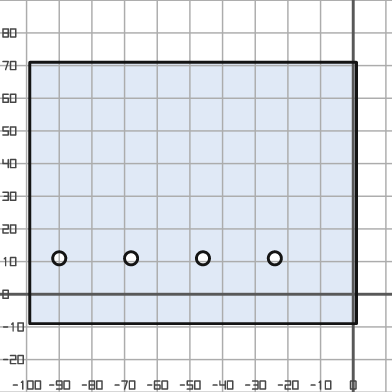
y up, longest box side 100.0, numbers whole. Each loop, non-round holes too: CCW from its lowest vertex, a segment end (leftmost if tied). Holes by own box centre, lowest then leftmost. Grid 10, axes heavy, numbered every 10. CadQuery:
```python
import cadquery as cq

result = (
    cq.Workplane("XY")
    .moveTo(-99.0, -9.0)
    .lineTo(1.0, -9.0)
    .lineTo(1.0, 71.0)
    .lineTo(-99.0, 71.0)
    .close()
    .moveTo(-90.0, 11.0)
    .circle(2.0)
    .moveTo(-68.0, 11.0)
    .circle(2.0)
    .moveTo(-46.0, 11.0)
    .circle(2.0)
    .moveTo(-24.0, 11.0)
    .circle(2.0)
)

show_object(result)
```